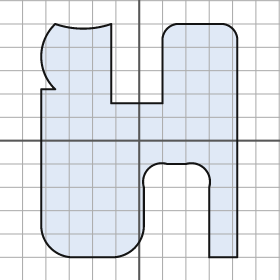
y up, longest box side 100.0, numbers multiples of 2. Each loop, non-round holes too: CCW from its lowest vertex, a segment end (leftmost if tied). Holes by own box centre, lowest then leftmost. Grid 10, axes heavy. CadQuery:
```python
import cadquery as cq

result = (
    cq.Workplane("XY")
    .moveTo(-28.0, -50.0)
    .lineTo(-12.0, -50.0)
    .threePointArc((-2.0, -46.0), (2.0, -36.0))
    .lineTo(2.0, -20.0)
    .threePointArc((4.0, -12.0), (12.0, -10.0))
    .lineTo(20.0, -10.0)
    .threePointArc((28.0, -12.0), (30.0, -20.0))
    .lineTo(30.0, -50.0)
    .lineTo(42.0, -50.0)
    .lineTo(42.0, 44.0)
    .threePointArc((40.0, 48.0), (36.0, 50.0))
    .lineTo(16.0, 50.0)
    .threePointArc((12.0, 48.0), (10.0, 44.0))
    .lineTo(10.0, 16.0)
    .lineTo(-12.0, 16.0)
    .lineTo(-12.0, 50.0)
    .threePointArc((-24.0, 48.0), (-36.0, 50.0))
    .threePointArc((-42.0, 36.0), (-36.0, 22.0))
    .lineTo(-42.0, 22.0)
    .lineTo(-42.0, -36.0)
    .threePointArc((-38.0, -46.0), (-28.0, -50.0))
    .close()
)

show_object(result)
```